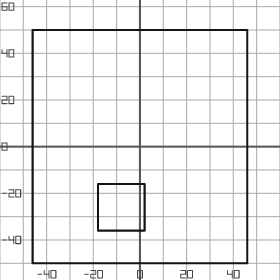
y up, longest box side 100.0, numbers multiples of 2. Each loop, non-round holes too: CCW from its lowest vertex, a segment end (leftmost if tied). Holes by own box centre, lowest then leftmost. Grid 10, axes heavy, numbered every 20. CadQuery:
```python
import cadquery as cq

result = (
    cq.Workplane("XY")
    .moveTo(-46.0, -50.0)
    .lineTo(46.0, -50.0)
    .lineTo(46.0, 50.0)
    .lineTo(-46.0, 50.0)
    .close()
    .moveTo(-18.0, -36.0)
    .lineTo(2.0, -36.0)
    .lineTo(2.0, -16.0)
    .lineTo(-18.0, -16.0)
    .close()
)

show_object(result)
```